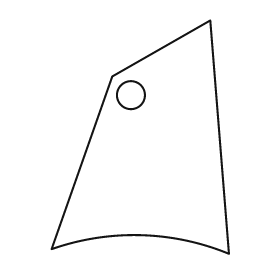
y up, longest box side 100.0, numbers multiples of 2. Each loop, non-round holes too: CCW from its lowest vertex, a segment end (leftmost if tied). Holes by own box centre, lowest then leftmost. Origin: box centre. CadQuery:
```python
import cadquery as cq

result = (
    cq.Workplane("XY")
    .moveTo(38.0, -50.0)
    .lineTo(30.0, 50.0)
    .lineTo(-12.0, 26.0)
    .lineTo(-38.0, -48.0)
    .threePointArc((0.0, -42.0), (38.0, -50.0))
    .close()
    .moveTo(-4.0, 18.0)
    .circle(6.0)
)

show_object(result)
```